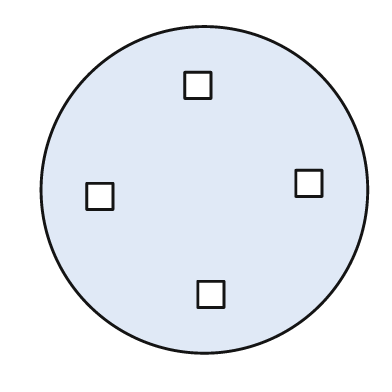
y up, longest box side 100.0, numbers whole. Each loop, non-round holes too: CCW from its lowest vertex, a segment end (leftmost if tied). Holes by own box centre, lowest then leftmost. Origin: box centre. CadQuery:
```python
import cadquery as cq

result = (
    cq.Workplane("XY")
    .moveTo(0.0, 0.0)
    .circle(50.0)
    .moveTo(-2.0, -36.0)
    .lineTo(6.0, -36.0)
    .lineTo(6.0, -28.0)
    .lineTo(-2.0, -28.0)
    .close()
    .moveTo(-36.0, -6.0)
    .lineTo(-28.0, -6.0)
    .lineTo(-28.0, 2.0)
    .lineTo(-36.0, 2.0)
    .close()
    .moveTo(28.0, -2.0)
    .lineTo(36.0, -2.0)
    .lineTo(36.0, 6.0)
    .lineTo(28.0, 6.0)
    .close()
    .moveTo(-6.0, 28.0)
    .lineTo(2.0, 28.0)
    .lineTo(2.0, 36.0)
    .lineTo(-6.0, 36.0)
    .close()
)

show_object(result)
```